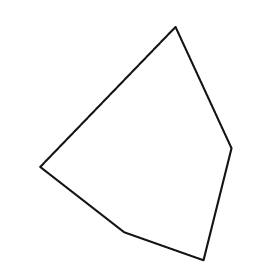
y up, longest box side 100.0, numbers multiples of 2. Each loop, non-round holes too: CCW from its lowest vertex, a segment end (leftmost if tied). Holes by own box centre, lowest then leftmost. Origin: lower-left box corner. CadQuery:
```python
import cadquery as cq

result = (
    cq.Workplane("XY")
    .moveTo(70.0, 0.0)
    .lineTo(82.0, 48.0)
    .lineTo(58.0, 100.0)
    .lineTo(0.0, 40.0)
    .lineTo(36.0, 12.0)
    .close()
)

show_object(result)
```